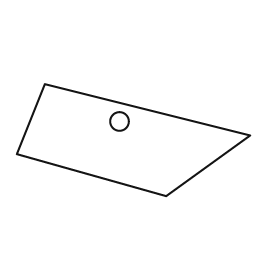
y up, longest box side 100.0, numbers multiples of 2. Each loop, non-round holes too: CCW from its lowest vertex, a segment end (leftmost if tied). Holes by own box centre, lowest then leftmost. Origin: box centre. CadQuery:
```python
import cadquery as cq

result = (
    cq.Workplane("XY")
    .moveTo(14.0, -24.0)
    .lineTo(50.0, 2.0)
    .lineTo(-38.0, 24.0)
    .lineTo(-50.0, -6.0)
    .close()
    .moveTo(-6.0, 8.0)
    .circle(4.0)
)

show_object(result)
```